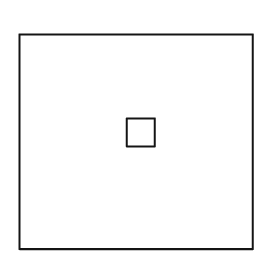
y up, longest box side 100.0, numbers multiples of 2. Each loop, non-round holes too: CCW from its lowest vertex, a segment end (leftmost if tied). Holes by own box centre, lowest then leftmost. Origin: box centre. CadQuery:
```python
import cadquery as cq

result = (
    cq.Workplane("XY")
    .moveTo(-50.0, -46.0)
    .lineTo(50.0, -46.0)
    .lineTo(50.0, 46.0)
    .lineTo(-50.0, 46.0)
    .close()
    .moveTo(-4.0, -2.0)
    .lineTo(8.0, -2.0)
    .lineTo(8.0, 10.0)
    .lineTo(-4.0, 10.0)
    .close()
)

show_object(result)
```